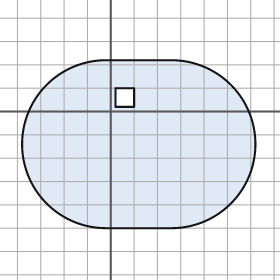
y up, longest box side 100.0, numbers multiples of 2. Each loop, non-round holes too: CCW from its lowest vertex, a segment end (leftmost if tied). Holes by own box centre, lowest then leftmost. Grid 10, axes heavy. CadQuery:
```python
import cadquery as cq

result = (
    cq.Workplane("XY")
    .moveTo(-2.0, -50.0)
    .lineTo(26.0, -50.0)
    .threePointArc((62.0, -14.0), (26.0, 22.0))
    .lineTo(-2.0, 22.0)
    .threePointArc((-38.0, -14.0), (-2.0, -50.0))
    .close()
    .moveTo(2.0, 2.0)
    .lineTo(10.0, 2.0)
    .lineTo(10.0, 10.0)
    .lineTo(2.0, 10.0)
    .close()
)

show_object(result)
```